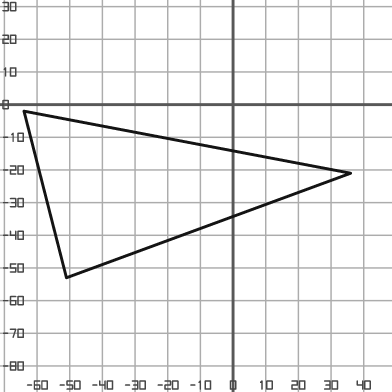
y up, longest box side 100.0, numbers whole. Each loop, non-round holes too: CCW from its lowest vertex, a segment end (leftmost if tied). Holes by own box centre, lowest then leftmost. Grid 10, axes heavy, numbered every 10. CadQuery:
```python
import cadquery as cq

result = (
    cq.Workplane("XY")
    .moveTo(-51.0, -53.0)
    .lineTo(36.0, -21.0)
    .lineTo(-64.0, -2.0)
    .close()
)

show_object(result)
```